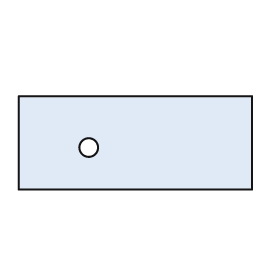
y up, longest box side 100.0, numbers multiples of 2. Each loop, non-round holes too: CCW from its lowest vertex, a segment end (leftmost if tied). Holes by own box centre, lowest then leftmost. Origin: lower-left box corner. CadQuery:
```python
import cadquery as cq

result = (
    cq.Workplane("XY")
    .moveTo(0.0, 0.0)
    .lineTo(100.0, 0.0)
    .lineTo(100.0, 40.0)
    .lineTo(0.0, 40.0)
    .close()
    .moveTo(30.0, 18.0)
    .circle(4.0)
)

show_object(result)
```